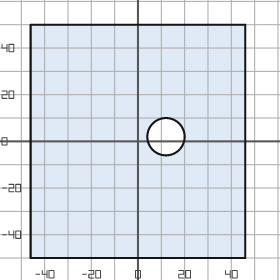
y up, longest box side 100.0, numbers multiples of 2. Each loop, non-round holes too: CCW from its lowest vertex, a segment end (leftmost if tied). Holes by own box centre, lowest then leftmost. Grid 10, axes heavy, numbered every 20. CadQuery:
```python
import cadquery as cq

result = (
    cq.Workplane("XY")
    .moveTo(-46.0, -50.0)
    .lineTo(46.0, -50.0)
    .lineTo(46.0, 50.0)
    .lineTo(-46.0, 50.0)
    .close()
    .moveTo(12.0, 2.0)
    .circle(8.0)
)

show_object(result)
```